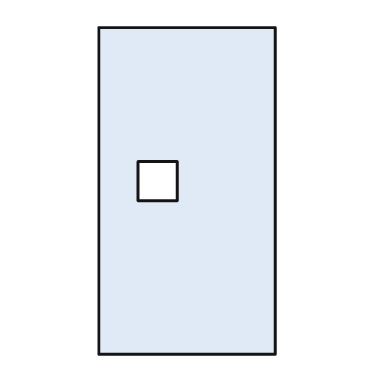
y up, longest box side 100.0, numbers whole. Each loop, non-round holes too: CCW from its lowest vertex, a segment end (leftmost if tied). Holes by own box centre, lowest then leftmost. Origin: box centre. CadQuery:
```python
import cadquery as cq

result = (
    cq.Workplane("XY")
    .moveTo(-27.0, -50.0)
    .lineTo(27.0, -50.0)
    .lineTo(27.0, 50.0)
    .lineTo(-27.0, 50.0)
    .close()
    .moveTo(-15.0, -3.0)
    .lineTo(-3.0, -3.0)
    .lineTo(-3.0, 9.0)
    .lineTo(-15.0, 9.0)
    .close()
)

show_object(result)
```